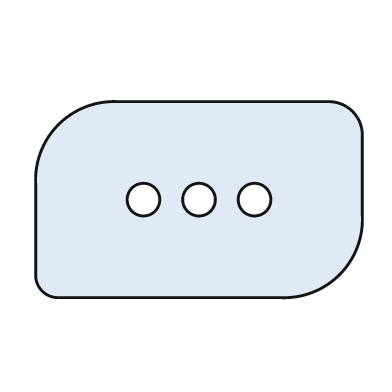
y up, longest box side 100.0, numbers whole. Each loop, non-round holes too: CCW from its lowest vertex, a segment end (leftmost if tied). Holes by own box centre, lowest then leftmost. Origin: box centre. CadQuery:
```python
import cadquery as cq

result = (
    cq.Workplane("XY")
    .moveTo(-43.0, -30.0)
    .lineTo(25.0, -30.0)
    .threePointArc((43.0, -23.0), (50.0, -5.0))
    .lineTo(50.0, 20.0)
    .threePointArc((47.0, 27.0), (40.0, 30.0))
    .lineTo(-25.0, 30.0)
    .threePointArc((-43.0, 23.0), (-50.0, 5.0))
    .lineTo(-50.0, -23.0)
    .threePointArc((-48.0, -28.0), (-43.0, -30.0))
    .close()
    .moveTo(-17.0, 0.0)
    .circle(5.0)
    .moveTo(0.0, 0.0)
    .circle(5.0)
    .moveTo(17.0, 0.0)
    .circle(5.0)
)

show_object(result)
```